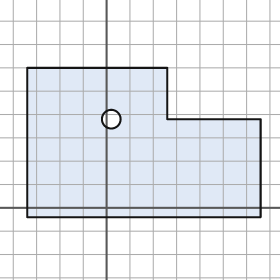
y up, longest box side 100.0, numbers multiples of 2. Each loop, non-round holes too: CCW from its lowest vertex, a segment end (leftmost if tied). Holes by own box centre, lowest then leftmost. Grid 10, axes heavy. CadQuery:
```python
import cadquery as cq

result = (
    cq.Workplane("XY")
    .moveTo(-34.0, -4.0)
    .lineTo(66.0, -4.0)
    .lineTo(66.0, 38.0)
    .lineTo(26.0, 38.0)
    .lineTo(26.0, 60.0)
    .lineTo(-34.0, 60.0)
    .close()
    .moveTo(2.0, 38.0)
    .circle(4.0)
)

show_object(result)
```